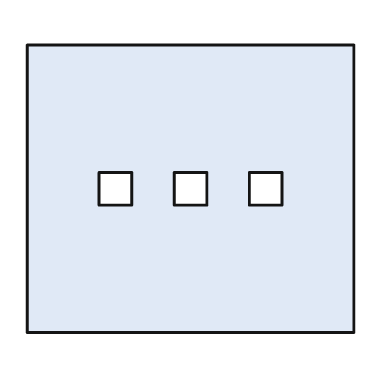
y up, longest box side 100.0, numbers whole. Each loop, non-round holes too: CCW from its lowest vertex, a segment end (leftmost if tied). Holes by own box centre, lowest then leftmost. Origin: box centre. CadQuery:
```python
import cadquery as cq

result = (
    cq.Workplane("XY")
    .moveTo(-50.0, -44.0)
    .lineTo(50.0, -44.0)
    .lineTo(50.0, 44.0)
    .lineTo(-50.0, 44.0)
    .close()
    .moveTo(-28.0, -5.0)
    .lineTo(-18.0, -5.0)
    .lineTo(-18.0, 5.0)
    .lineTo(-28.0, 5.0)
    .close()
    .moveTo(-5.0, -5.0)
    .lineTo(5.0, -5.0)
    .lineTo(5.0, 5.0)
    .lineTo(-5.0, 5.0)
    .close()
    .moveTo(18.0, -5.0)
    .lineTo(28.0, -5.0)
    .lineTo(28.0, 5.0)
    .lineTo(18.0, 5.0)
    .close()
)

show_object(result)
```